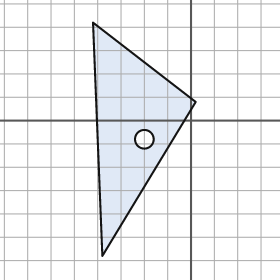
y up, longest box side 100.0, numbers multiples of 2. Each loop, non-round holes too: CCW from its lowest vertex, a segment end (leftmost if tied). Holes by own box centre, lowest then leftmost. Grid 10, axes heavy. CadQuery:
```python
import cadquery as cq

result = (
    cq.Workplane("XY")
    .moveTo(-38.0, -58.0)
    .lineTo(2.0, 8.0)
    .lineTo(-42.0, 42.0)
    .close()
    .moveTo(-20.0, -8.0)
    .circle(4.0)
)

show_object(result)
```